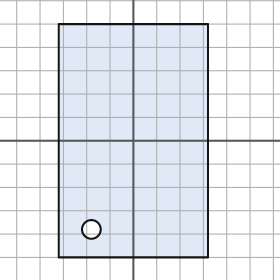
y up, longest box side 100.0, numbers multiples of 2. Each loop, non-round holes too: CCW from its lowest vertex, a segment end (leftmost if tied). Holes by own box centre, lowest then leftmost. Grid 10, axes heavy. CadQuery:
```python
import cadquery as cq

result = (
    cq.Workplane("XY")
    .moveTo(-32.0, -50.0)
    .lineTo(32.0, -50.0)
    .lineTo(32.0, 50.0)
    .lineTo(-32.0, 50.0)
    .close()
    .moveTo(-18.0, -38.0)
    .circle(4.0)
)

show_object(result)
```